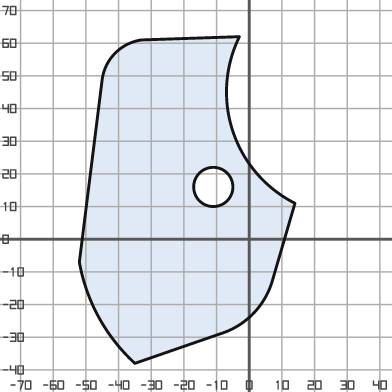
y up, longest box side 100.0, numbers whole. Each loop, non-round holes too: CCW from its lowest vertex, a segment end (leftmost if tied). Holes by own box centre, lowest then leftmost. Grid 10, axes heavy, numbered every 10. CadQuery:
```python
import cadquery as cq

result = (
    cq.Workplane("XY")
    .moveTo(-35.0, -38.0)
    .lineTo(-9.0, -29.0)
    .threePointArc((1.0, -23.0), (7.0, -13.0))
    .lineTo(14.0, 11.0)
    .threePointArc((-5.0, 33.0), (-3.0, 62.0))
    .lineTo(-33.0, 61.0)
    .threePointArc((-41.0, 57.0), (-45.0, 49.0))
    .lineTo(-52.0, -7.0)
    .threePointArc((-46.0, -24.0), (-35.0, -38.0))
    .close()
    .moveTo(-11.0, 16.0)
    .circle(6.0)
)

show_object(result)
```